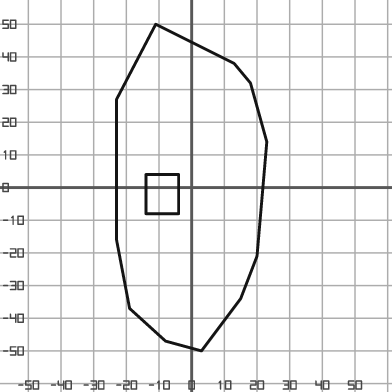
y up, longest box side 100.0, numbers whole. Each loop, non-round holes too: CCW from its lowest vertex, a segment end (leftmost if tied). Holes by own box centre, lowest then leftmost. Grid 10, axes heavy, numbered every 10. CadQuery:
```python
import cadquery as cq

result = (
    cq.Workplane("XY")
    .moveTo(3.0, -50.0)
    .lineTo(15.0, -34.0)
    .lineTo(20.0, -21.0)
    .lineTo(23.0, 14.0)
    .lineTo(18.0, 32.0)
    .lineTo(13.0, 38.0)
    .lineTo(-11.0, 50.0)
    .lineTo(-23.0, 27.0)
    .lineTo(-23.0, -16.0)
    .lineTo(-19.0, -37.0)
    .lineTo(-8.0, -47.0)
    .close()
    .moveTo(-14.0, -8.0)
    .lineTo(-4.0, -8.0)
    .lineTo(-4.0, 4.0)
    .lineTo(-14.0, 4.0)
    .close()
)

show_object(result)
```